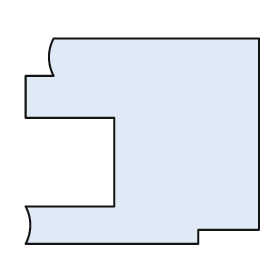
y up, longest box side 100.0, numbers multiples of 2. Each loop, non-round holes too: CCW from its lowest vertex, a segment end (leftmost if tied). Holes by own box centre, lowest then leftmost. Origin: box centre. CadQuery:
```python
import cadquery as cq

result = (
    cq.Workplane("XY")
    .moveTo(-50.0, -44.0)
    .lineTo(24.0, -44.0)
    .lineTo(24.0, -38.0)
    .lineTo(50.0, -38.0)
    .lineTo(50.0, 44.0)
    .lineTo(-38.0, 44.0)
    .threePointArc((-40.0, 36.0), (-38.0, 28.0))
    .lineTo(-50.0, 28.0)
    .lineTo(-50.0, 10.0)
    .lineTo(-12.0, 10.0)
    .lineTo(-12.0, -28.0)
    .lineTo(-50.0, -28.0)
    .threePointArc((-48.0, -36.0), (-50.0, -44.0))
    .close()
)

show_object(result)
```